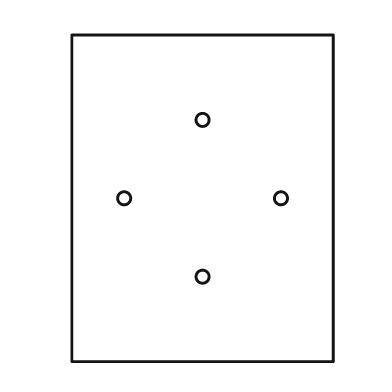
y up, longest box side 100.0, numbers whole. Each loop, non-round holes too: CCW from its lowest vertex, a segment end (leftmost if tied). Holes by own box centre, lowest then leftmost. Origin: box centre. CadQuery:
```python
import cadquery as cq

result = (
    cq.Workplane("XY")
    .moveTo(-40.0, -50.0)
    .lineTo(40.0, -50.0)
    .lineTo(40.0, 50.0)
    .lineTo(-40.0, 50.0)
    .close()
    .moveTo(0.0, -24.0)
    .circle(2.0)
    .moveTo(-24.0, 0.0)
    .circle(2.0)
    .moveTo(24.0, 0.0)
    .circle(2.0)
    .moveTo(0.0, 24.0)
    .circle(2.0)
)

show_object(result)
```